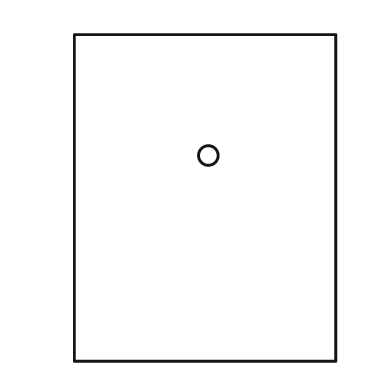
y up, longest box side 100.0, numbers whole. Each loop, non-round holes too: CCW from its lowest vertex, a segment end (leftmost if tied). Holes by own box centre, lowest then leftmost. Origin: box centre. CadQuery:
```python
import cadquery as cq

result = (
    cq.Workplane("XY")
    .moveTo(-40.0, -50.0)
    .lineTo(40.0, -50.0)
    .lineTo(40.0, 50.0)
    .lineTo(-40.0, 50.0)
    .close()
    .moveTo(1.0, 13.0)
    .circle(3.0)
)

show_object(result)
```